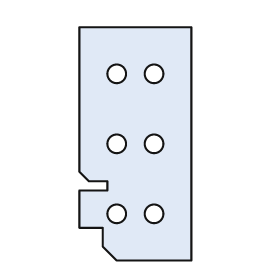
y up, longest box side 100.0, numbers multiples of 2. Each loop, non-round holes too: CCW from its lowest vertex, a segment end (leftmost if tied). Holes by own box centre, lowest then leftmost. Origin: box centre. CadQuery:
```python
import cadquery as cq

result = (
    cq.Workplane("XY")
    .moveTo(-8.0, -50.0)
    .lineTo(24.0, -50.0)
    .lineTo(24.0, 50.0)
    .lineTo(-24.0, 50.0)
    .lineTo(-24.0, -12.0)
    .lineTo(-20.0, -16.0)
    .lineTo(-12.0, -16.0)
    .lineTo(-12.0, -20.0)
    .lineTo(-24.0, -20.0)
    .lineTo(-24.0, -36.0)
    .lineTo(-14.0, -36.0)
    .lineTo(-14.0, -44.0)
    .close()
    .moveTo(-8.0, -30.0)
    .circle(4.0)
    .moveTo(8.0, -30.0)
    .circle(4.0)
    .moveTo(-8.0, 0.0)
    .circle(4.0)
    .moveTo(8.0, 0.0)
    .circle(4.0)
    .moveTo(-8.0, 30.0)
    .circle(4.0)
    .moveTo(8.0, 30.0)
    .circle(4.0)
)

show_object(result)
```